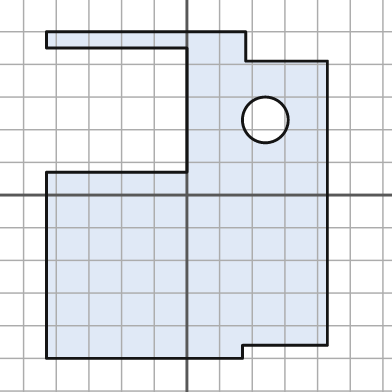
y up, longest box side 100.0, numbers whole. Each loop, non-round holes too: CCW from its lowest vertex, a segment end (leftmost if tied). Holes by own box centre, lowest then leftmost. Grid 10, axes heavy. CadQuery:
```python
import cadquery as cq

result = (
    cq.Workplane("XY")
    .moveTo(-43.0, -50.0)
    .lineTo(17.0, -50.0)
    .lineTo(17.0, -46.0)
    .lineTo(43.0, -46.0)
    .lineTo(43.0, 41.0)
    .lineTo(18.0, 41.0)
    .lineTo(18.0, 50.0)
    .lineTo(-43.0, 50.0)
    .lineTo(-43.0, 45.0)
    .lineTo(0.0, 45.0)
    .lineTo(0.0, 7.0)
    .lineTo(-43.0, 7.0)
    .close()
    .moveTo(24.0, 23.0)
    .circle(7.0)
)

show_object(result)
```